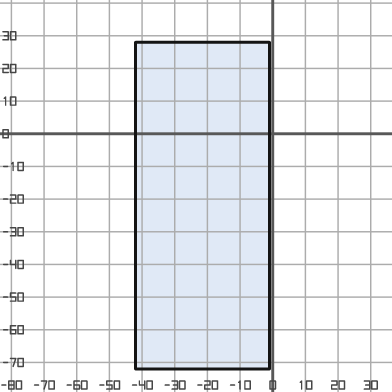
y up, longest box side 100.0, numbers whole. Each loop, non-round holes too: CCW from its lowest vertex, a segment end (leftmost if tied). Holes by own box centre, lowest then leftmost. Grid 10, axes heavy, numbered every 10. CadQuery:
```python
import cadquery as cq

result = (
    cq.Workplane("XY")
    .moveTo(-42.0, -72.0)
    .lineTo(-1.0, -72.0)
    .lineTo(-1.0, 28.0)
    .lineTo(-42.0, 28.0)
    .close()
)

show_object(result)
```